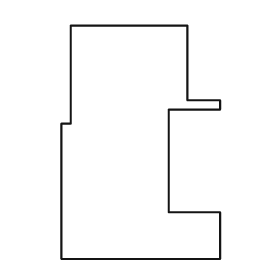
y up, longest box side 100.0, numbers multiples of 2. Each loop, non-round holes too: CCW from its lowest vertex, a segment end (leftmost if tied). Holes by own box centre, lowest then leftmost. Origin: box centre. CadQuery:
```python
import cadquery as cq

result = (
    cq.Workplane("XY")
    .moveTo(-34.0, -50.0)
    .lineTo(34.0, -50.0)
    .lineTo(34.0, -30.0)
    .lineTo(12.0, -30.0)
    .lineTo(12.0, 14.0)
    .lineTo(34.0, 14.0)
    .lineTo(34.0, 18.0)
    .lineTo(20.0, 18.0)
    .lineTo(20.0, 50.0)
    .lineTo(-30.0, 50.0)
    .lineTo(-30.0, 8.0)
    .lineTo(-34.0, 8.0)
    .close()
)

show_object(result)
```